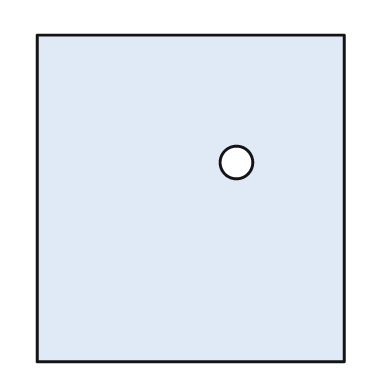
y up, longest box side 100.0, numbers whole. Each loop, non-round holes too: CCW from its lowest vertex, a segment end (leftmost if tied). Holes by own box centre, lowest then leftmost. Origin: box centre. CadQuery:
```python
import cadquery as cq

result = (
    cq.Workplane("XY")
    .moveTo(-47.0, -50.0)
    .lineTo(47.0, -50.0)
    .lineTo(47.0, 50.0)
    .lineTo(-47.0, 50.0)
    .close()
    .moveTo(14.0, 11.0)
    .circle(5.0)
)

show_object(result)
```